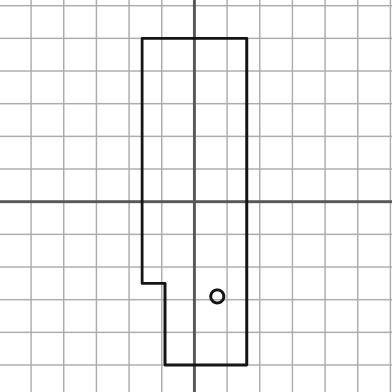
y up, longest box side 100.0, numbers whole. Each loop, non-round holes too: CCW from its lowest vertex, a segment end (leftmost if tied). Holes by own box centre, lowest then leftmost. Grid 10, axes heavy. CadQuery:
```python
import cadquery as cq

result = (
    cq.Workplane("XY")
    .moveTo(-9.0, -50.0)
    .lineTo(16.0, -50.0)
    .lineTo(16.0, 50.0)
    .lineTo(-16.0, 50.0)
    .lineTo(-16.0, -25.0)
    .lineTo(-9.0, -25.0)
    .close()
    .moveTo(7.0, -29.0)
    .circle(2.0)
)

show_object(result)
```